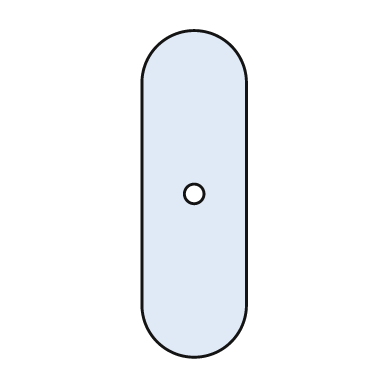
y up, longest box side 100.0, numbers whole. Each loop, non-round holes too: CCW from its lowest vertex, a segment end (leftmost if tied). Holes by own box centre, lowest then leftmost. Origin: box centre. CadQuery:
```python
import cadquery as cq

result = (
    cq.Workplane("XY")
    .moveTo(-16.0, -34.0)
    .threePointArc((0.0, -50.0), (16.0, -34.0))
    .lineTo(16.0, 34.0)
    .threePointArc((0.0, 50.0), (-16.0, 34.0))
    .close()
    .moveTo(0.0, 0.0)
    .circle(3.0)
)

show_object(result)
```